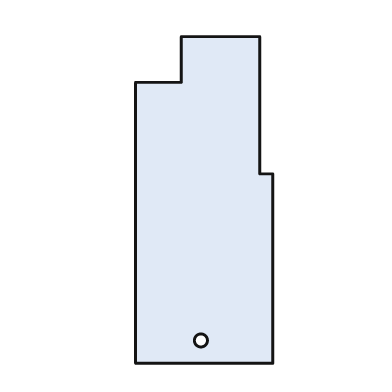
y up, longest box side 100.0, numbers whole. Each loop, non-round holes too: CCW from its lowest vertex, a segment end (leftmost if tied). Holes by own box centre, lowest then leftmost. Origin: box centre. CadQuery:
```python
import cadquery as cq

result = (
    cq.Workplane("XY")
    .moveTo(-21.0, -50.0)
    .lineTo(21.0, -50.0)
    .lineTo(21.0, 8.0)
    .lineTo(17.0, 8.0)
    .lineTo(17.0, 50.0)
    .lineTo(-7.0, 50.0)
    .lineTo(-7.0, 36.0)
    .lineTo(-21.0, 36.0)
    .close()
    .moveTo(-1.0, -43.0)
    .circle(2.0)
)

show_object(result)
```